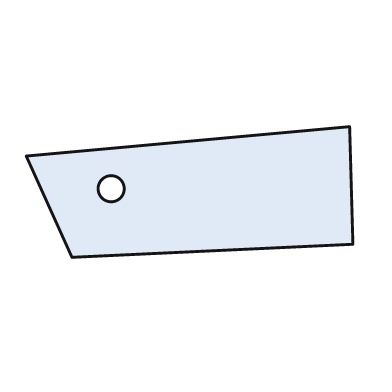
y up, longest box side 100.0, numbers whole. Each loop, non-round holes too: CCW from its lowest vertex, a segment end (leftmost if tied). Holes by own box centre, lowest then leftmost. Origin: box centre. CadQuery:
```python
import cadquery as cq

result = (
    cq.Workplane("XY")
    .moveTo(-36.0, -20.0)
    .lineTo(50.0, -16.0)
    .lineTo(49.0, 20.0)
    .lineTo(-50.0, 11.0)
    .close()
    .moveTo(-24.0, 1.0)
    .circle(4.0)
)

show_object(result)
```